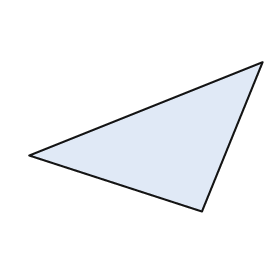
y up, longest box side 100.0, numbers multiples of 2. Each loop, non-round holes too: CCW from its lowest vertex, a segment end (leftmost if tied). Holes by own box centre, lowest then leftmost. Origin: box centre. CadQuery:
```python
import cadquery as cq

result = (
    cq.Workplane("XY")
    .moveTo(24.0, -32.0)
    .lineTo(50.0, 32.0)
    .lineTo(-50.0, -8.0)
    .close()
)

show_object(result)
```